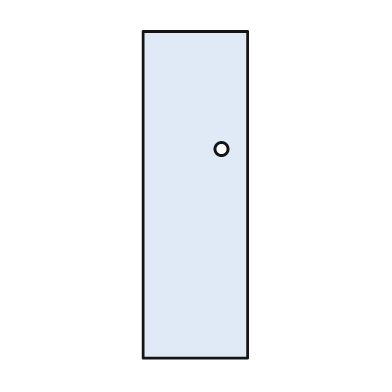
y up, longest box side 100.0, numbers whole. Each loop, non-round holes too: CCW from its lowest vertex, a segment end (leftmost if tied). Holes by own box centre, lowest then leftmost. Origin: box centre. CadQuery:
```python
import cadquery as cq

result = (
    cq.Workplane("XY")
    .moveTo(-16.0, -50.0)
    .lineTo(16.0, -50.0)
    .lineTo(16.0, 50.0)
    .lineTo(-16.0, 50.0)
    .close()
    .moveTo(8.0, 14.0)
    .circle(2.0)
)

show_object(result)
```